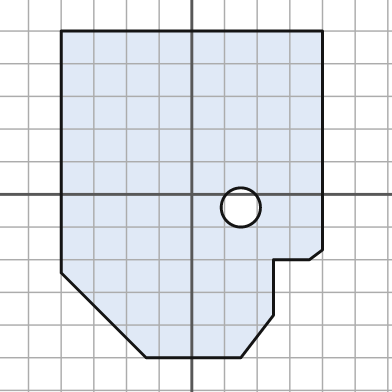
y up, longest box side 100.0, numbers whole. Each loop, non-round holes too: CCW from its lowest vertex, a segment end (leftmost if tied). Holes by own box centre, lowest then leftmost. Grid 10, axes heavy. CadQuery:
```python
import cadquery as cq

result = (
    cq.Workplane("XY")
    .moveTo(-14.0, -50.0)
    .lineTo(15.0, -50.0)
    .lineTo(25.0, -37.0)
    .lineTo(25.0, -20.0)
    .lineTo(36.0, -20.0)
    .lineTo(40.0, -17.0)
    .lineTo(40.0, 50.0)
    .lineTo(-40.0, 50.0)
    .lineTo(-40.0, -24.0)
    .close()
    .moveTo(15.0, -4.0)
    .circle(6.0)
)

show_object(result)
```